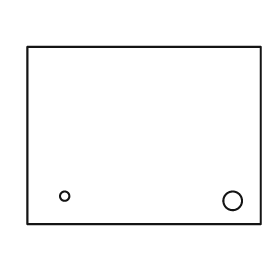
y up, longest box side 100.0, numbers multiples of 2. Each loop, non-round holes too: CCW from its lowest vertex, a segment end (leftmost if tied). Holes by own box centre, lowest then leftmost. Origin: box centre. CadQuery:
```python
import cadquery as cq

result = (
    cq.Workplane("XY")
    .moveTo(-50.0, -38.0)
    .lineTo(50.0, -38.0)
    .lineTo(50.0, 38.0)
    .lineTo(-50.0, 38.0)
    .close()
    .moveTo(38.0, -28.0)
    .circle(4.0)
    .moveTo(-34.0, -26.0)
    .circle(2.0)
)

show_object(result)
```